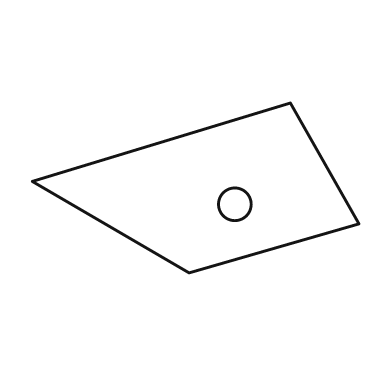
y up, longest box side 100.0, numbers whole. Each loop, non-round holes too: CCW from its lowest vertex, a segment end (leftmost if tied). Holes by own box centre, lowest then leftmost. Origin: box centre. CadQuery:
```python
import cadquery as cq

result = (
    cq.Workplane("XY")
    .moveTo(-2.0, -26.0)
    .lineTo(50.0, -11.0)
    .lineTo(29.0, 26.0)
    .lineTo(-50.0, 2.0)
    .close()
    .moveTo(12.0, -5.0)
    .circle(5.0)
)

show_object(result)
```